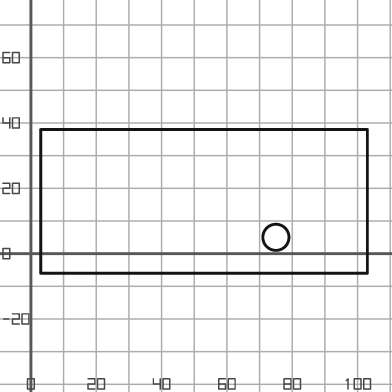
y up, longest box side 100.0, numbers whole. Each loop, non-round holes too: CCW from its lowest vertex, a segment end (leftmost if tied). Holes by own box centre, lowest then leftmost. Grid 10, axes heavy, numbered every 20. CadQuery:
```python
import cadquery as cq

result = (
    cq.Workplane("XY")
    .moveTo(3.0, -6.0)
    .lineTo(103.0, -6.0)
    .lineTo(103.0, 38.0)
    .lineTo(3.0, 38.0)
    .close()
    .moveTo(75.0, 5.0)
    .circle(4.0)
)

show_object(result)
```